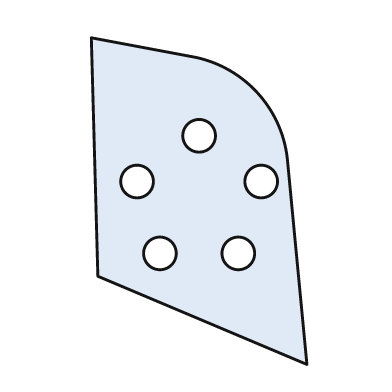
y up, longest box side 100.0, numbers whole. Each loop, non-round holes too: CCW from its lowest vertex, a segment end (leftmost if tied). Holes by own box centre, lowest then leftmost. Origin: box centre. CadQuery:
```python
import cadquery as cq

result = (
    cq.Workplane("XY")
    .moveTo(33.0, -50.0)
    .lineTo(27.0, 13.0)
    .threePointArc((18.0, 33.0), (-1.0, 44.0))
    .lineTo(-33.0, 50.0)
    .lineTo(-31.0, -23.0)
    .close()
    .moveTo(-12.0, -16.0)
    .circle(5.0)
    .moveTo(12.0, -16.0)
    .circle(5.0)
    .moveTo(-19.0, 6.0)
    .circle(5.0)
    .moveTo(19.0, 6.0)
    .circle(5.0)
    .moveTo(0.0, 20.0)
    .circle(5.0)
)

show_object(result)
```